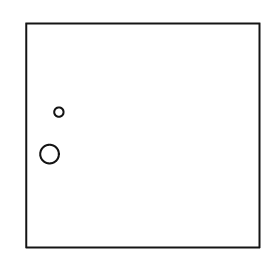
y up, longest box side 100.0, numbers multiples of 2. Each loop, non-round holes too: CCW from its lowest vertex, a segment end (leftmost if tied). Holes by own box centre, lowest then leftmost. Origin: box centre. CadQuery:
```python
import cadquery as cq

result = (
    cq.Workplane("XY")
    .moveTo(-50.0, -48.0)
    .lineTo(50.0, -48.0)
    .lineTo(50.0, 48.0)
    .lineTo(-50.0, 48.0)
    .close()
    .moveTo(-40.0, -8.0)
    .circle(4.0)
    .moveTo(-36.0, 10.0)
    .circle(2.0)
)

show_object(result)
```